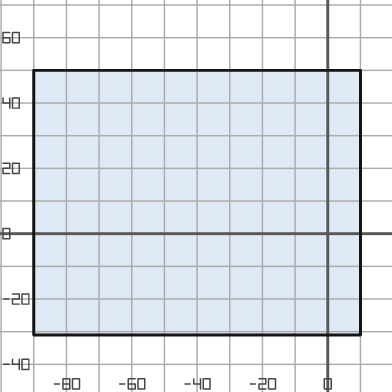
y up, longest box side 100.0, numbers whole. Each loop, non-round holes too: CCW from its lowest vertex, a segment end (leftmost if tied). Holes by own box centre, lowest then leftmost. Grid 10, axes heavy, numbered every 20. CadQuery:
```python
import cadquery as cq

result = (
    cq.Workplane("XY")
    .moveTo(-90.0, -31.0)
    .lineTo(10.0, -31.0)
    .lineTo(10.0, 50.0)
    .lineTo(-90.0, 50.0)
    .close()
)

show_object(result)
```